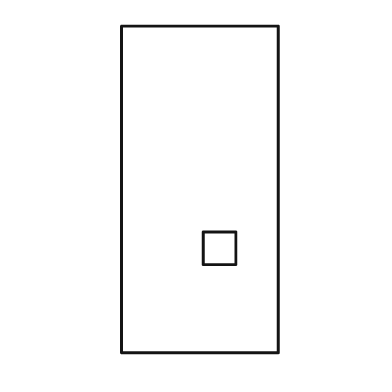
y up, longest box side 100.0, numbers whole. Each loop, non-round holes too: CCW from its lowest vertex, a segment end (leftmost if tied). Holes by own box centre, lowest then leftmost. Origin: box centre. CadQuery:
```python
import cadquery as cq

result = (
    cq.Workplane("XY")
    .moveTo(-24.0, -50.0)
    .lineTo(24.0, -50.0)
    .lineTo(24.0, 50.0)
    .lineTo(-24.0, 50.0)
    .close()
    .moveTo(1.0, -23.0)
    .lineTo(11.0, -23.0)
    .lineTo(11.0, -13.0)
    .lineTo(1.0, -13.0)
    .close()
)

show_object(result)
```